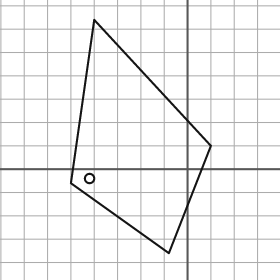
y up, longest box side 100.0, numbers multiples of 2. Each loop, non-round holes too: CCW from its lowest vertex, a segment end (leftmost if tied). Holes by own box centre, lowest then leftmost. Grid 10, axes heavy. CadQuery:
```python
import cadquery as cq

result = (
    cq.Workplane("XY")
    .moveTo(-8.0, -36.0)
    .lineTo(10.0, 10.0)
    .lineTo(-40.0, 64.0)
    .lineTo(-50.0, -6.0)
    .close()
    .moveTo(-42.0, -4.0)
    .circle(2.0)
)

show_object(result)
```